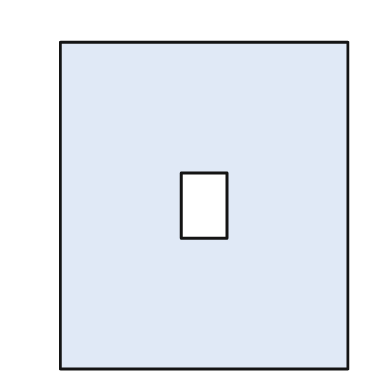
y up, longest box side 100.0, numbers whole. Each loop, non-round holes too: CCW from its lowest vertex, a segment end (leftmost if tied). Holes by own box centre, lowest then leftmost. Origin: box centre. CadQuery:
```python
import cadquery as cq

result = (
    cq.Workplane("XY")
    .moveTo(-44.0, -50.0)
    .lineTo(44.0, -50.0)
    .lineTo(44.0, 50.0)
    .lineTo(-44.0, 50.0)
    .close()
    .moveTo(-7.0, -10.0)
    .lineTo(7.0, -10.0)
    .lineTo(7.0, 10.0)
    .lineTo(-7.0, 10.0)
    .close()
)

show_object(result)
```